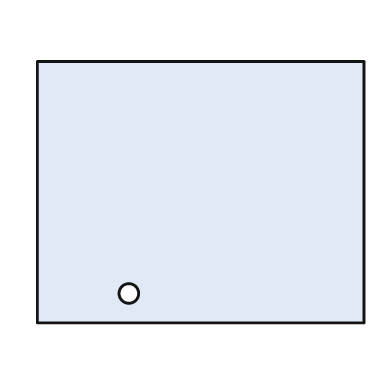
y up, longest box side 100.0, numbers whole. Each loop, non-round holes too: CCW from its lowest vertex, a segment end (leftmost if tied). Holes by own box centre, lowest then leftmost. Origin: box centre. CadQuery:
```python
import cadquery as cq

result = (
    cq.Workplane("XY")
    .moveTo(-50.0, -40.0)
    .lineTo(50.0, -40.0)
    .lineTo(50.0, 40.0)
    .lineTo(-50.0, 40.0)
    .close()
    .moveTo(-22.0, -31.0)
    .circle(3.0)
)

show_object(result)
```